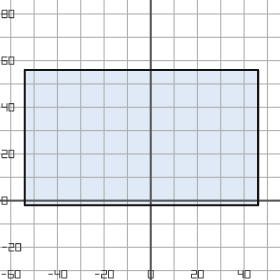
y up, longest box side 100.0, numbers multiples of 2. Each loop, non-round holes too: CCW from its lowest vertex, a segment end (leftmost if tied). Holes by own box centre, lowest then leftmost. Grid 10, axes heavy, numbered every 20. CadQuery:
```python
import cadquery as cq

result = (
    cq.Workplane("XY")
    .moveTo(-54.0, -2.0)
    .lineTo(46.0, -2.0)
    .lineTo(46.0, 56.0)
    .lineTo(-54.0, 56.0)
    .close()
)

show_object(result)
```